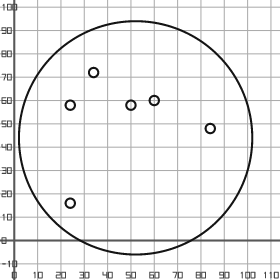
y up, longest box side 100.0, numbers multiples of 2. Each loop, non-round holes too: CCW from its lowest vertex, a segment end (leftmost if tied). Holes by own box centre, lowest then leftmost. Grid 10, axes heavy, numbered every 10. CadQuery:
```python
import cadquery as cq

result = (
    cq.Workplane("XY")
    .moveTo(52.0, 44.0)
    .circle(50.0)
    .moveTo(24.0, 16.0)
    .circle(2.0)
    .moveTo(84.0, 48.0)
    .circle(2.0)
    .moveTo(24.0, 58.0)
    .circle(2.0)
    .moveTo(50.0, 58.0)
    .circle(2.0)
    .moveTo(60.0, 60.0)
    .circle(2.0)
    .moveTo(34.0, 72.0)
    .circle(2.0)
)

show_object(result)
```